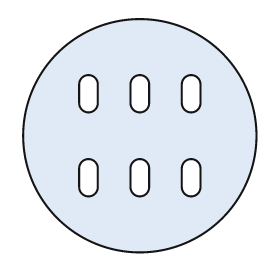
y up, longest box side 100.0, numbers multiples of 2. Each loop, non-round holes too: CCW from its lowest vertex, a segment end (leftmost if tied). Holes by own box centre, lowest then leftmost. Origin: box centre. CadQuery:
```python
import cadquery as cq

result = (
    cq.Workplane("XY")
    .moveTo(0.0, 0.0)
    .circle(50.0)
    .moveTo(-26.0, -22.0)
    .threePointArc((-22.0, -26.0), (-18.0, -22.0))
    .lineTo(-18.0, -14.0)
    .threePointArc((-22.0, -10.0), (-26.0, -14.0))
    .close()
    .moveTo(-4.0, -22.0)
    .threePointArc((0.0, -26.0), (4.0, -22.0))
    .lineTo(4.0, -14.0)
    .threePointArc((0.0, -10.0), (-4.0, -14.0))
    .close()
    .moveTo(18.0, -22.0)
    .threePointArc((22.0, -26.0), (26.0, -22.0))
    .lineTo(26.0, -14.0)
    .threePointArc((22.0, -10.0), (18.0, -14.0))
    .close()
    .moveTo(-26.0, 14.0)
    .threePointArc((-22.0, 10.0), (-18.0, 14.0))
    .lineTo(-18.0, 22.0)
    .threePointArc((-22.0, 26.0), (-26.0, 22.0))
    .close()
    .moveTo(-4.0, 14.0)
    .threePointArc((0.0, 10.0), (4.0, 14.0))
    .lineTo(4.0, 22.0)
    .threePointArc((0.0, 26.0), (-4.0, 22.0))
    .close()
    .moveTo(18.0, 14.0)
    .threePointArc((22.0, 10.0), (26.0, 14.0))
    .lineTo(26.0, 22.0)
    .threePointArc((22.0, 26.0), (18.0, 22.0))
    .close()
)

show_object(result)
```